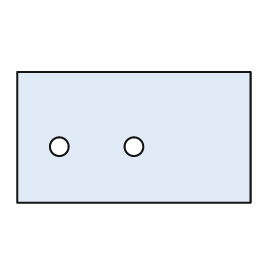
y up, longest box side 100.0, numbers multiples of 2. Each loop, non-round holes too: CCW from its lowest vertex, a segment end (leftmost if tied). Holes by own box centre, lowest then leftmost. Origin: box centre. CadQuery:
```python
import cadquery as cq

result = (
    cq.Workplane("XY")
    .moveTo(-50.0, -28.0)
    .lineTo(50.0, -28.0)
    .lineTo(50.0, 28.0)
    .lineTo(-50.0, 28.0)
    .close()
    .moveTo(-32.0, -4.0)
    .circle(4.0)
    .moveTo(0.0, -4.0)
    .circle(4.0)
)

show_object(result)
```